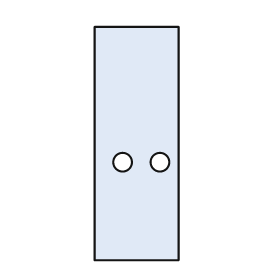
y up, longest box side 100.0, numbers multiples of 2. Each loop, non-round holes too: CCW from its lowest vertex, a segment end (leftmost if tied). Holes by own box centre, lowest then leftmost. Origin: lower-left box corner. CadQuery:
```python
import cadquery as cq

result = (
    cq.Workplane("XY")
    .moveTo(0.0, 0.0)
    .lineTo(36.0, 0.0)
    .lineTo(36.0, 100.0)
    .lineTo(0.0, 100.0)
    .close()
    .moveTo(12.0, 42.0)
    .circle(4.0)
    .moveTo(28.0, 42.0)
    .circle(4.0)
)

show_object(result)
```